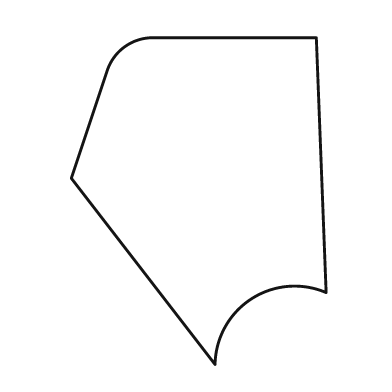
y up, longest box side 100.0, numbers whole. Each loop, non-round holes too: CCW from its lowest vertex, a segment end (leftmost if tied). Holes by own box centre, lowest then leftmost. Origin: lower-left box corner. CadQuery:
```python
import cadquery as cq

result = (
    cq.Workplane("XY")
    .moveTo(44.0, 0.0)
    .threePointArc((55.0, 20.0), (78.0, 22.0))
    .lineTo(75.0, 100.0)
    .lineTo(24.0, 100.0)
    .threePointArc((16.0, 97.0), (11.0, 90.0))
    .lineTo(0.0, 57.0)
    .close()
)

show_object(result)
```